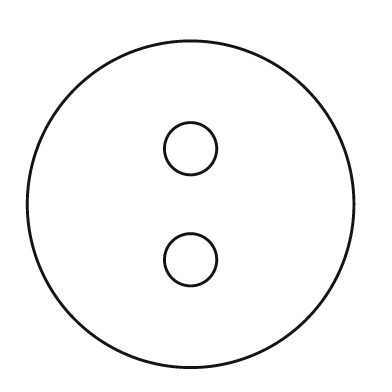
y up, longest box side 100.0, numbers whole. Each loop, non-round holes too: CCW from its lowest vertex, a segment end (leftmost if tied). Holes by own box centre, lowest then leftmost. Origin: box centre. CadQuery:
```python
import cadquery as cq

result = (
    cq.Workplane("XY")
    .moveTo(0.0, 0.0)
    .circle(50.0)
    .moveTo(0.0, -17.0)
    .circle(8.0)
    .moveTo(0.0, 17.0)
    .circle(8.0)
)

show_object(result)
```